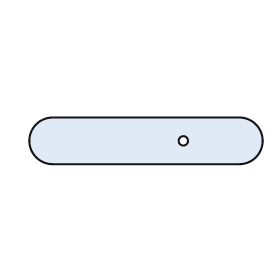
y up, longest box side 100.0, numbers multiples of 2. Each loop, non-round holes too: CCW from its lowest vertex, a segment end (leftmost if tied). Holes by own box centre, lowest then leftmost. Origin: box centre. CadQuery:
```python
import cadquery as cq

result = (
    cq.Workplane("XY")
    .moveTo(-40.0, -10.0)
    .lineTo(40.0, -10.0)
    .threePointArc((50.0, 0.0), (40.0, 10.0))
    .lineTo(-40.0, 10.0)
    .threePointArc((-50.0, 0.0), (-40.0, -10.0))
    .close()
    .moveTo(16.0, 0.0)
    .circle(2.0)
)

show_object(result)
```